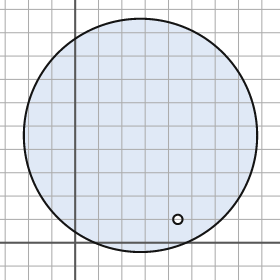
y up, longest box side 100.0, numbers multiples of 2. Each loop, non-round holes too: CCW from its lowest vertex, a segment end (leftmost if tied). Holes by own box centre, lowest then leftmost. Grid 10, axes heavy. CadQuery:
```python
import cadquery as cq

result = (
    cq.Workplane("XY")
    .moveTo(28.0, 46.0)
    .circle(50.0)
    .moveTo(44.0, 10.0)
    .circle(2.0)
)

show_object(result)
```